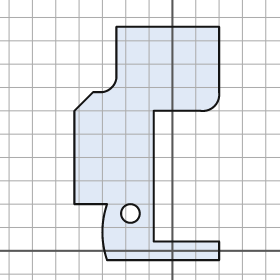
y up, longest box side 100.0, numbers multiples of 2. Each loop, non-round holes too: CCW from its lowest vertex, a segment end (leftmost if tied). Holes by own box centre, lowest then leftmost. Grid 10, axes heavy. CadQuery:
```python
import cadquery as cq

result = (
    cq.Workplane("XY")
    .moveTo(-28.0, -4.0)
    .lineTo(20.0, -4.0)
    .lineTo(20.0, 4.0)
    .lineTo(-8.0, 4.0)
    .lineTo(-8.0, 60.0)
    .lineTo(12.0, 60.0)
    .threePointArc((18.0, 62.0), (20.0, 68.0))
    .lineTo(20.0, 96.0)
    .lineTo(-24.0, 96.0)
    .lineTo(-24.0, 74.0)
    .threePointArc((-26.0, 70.0), (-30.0, 68.0))
    .lineTo(-34.0, 68.0)
    .lineTo(-42.0, 60.0)
    .lineTo(-42.0, 20.0)
    .lineTo(-28.0, 20.0)
    .threePointArc((-30.0, 8.0), (-28.0, -4.0))
    .close()
    .moveTo(-18.0, 16.0)
    .circle(4.0)
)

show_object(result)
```